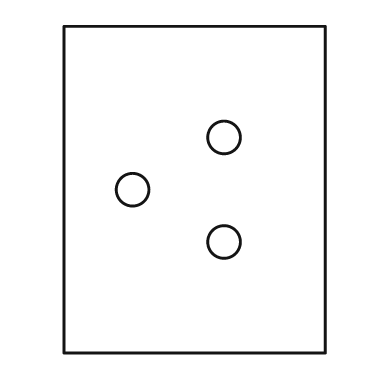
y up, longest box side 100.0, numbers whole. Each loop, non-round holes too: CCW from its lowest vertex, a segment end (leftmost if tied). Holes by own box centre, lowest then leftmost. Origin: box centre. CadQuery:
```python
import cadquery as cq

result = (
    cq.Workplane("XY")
    .moveTo(-40.0, -50.0)
    .lineTo(40.0, -50.0)
    .lineTo(40.0, 50.0)
    .lineTo(-40.0, 50.0)
    .close()
    .moveTo(9.0, -16.0)
    .circle(5.0)
    .moveTo(-19.0, 0.0)
    .circle(5.0)
    .moveTo(9.0, 16.0)
    .circle(5.0)
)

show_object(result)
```